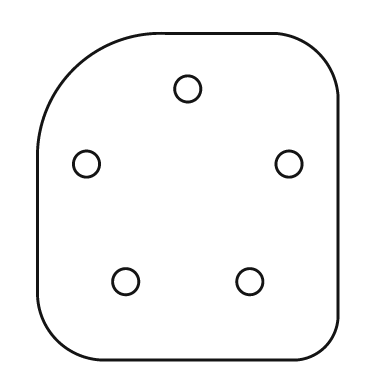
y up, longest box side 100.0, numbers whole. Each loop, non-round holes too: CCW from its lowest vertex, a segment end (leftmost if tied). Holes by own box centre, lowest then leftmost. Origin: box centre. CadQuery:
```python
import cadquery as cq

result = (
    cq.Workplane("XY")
    .moveTo(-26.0, -50.0)
    .lineTo(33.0, -50.0)
    .threePointArc((42.0, -46.0), (46.0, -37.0))
    .lineTo(46.0, 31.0)
    .threePointArc((40.0, 44.0), (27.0, 50.0))
    .lineTo(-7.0, 50.0)
    .threePointArc((-35.0, 39.0), (-46.0, 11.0))
    .lineTo(-46.0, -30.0)
    .threePointArc((-40.0, -44.0), (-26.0, -50.0))
    .close()
    .moveTo(-19.0, -26.0)
    .circle(4.0)
    .moveTo(19.0, -26.0)
    .circle(4.0)
    .moveTo(-31.0, 10.0)
    .circle(4.0)
    .moveTo(31.0, 10.0)
    .circle(4.0)
    .moveTo(0.0, 33.0)
    .circle(4.0)
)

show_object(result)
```